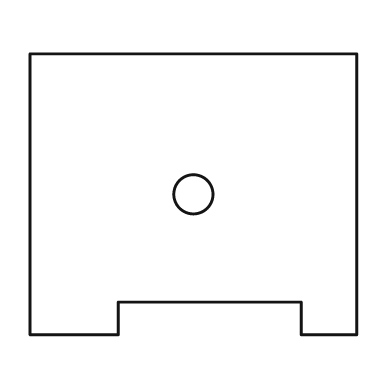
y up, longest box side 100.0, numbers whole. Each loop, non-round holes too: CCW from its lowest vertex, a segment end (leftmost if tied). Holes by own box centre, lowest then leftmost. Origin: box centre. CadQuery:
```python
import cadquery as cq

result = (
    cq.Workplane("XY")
    .moveTo(-50.0, -43.0)
    .lineTo(-23.0, -43.0)
    .lineTo(-23.0, -33.0)
    .lineTo(33.0, -33.0)
    .lineTo(33.0, -43.0)
    .lineTo(50.0, -43.0)
    .lineTo(50.0, 43.0)
    .lineTo(-50.0, 43.0)
    .close()
    .moveTo(0.0, 0.0)
    .circle(6.0)
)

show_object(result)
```